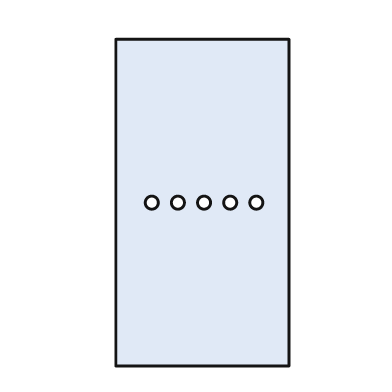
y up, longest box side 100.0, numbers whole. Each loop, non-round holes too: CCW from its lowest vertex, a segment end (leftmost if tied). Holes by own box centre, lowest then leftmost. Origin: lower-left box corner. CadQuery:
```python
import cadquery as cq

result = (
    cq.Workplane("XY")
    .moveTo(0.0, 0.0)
    .lineTo(53.0, 0.0)
    .lineTo(53.0, 100.0)
    .lineTo(0.0, 100.0)
    .close()
    .moveTo(11.0, 50.0)
    .circle(2.0)
    .moveTo(19.0, 50.0)
    .circle(2.0)
    .moveTo(27.0, 50.0)
    .circle(2.0)
    .moveTo(35.0, 50.0)
    .circle(2.0)
    .moveTo(43.0, 50.0)
    .circle(2.0)
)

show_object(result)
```